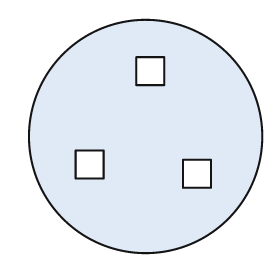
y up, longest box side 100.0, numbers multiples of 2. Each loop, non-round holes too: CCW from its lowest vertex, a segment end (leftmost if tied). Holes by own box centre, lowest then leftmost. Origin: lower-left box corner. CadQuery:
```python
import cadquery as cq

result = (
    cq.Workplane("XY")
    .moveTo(50.0, 50.0)
    .circle(50.0)
    .moveTo(66.0, 28.0)
    .lineTo(78.0, 28.0)
    .lineTo(78.0, 40.0)
    .lineTo(66.0, 40.0)
    .close()
    .moveTo(20.0, 32.0)
    .lineTo(32.0, 32.0)
    .lineTo(32.0, 44.0)
    .lineTo(20.0, 44.0)
    .close()
    .moveTo(46.0, 72.0)
    .lineTo(58.0, 72.0)
    .lineTo(58.0, 84.0)
    .lineTo(46.0, 84.0)
    .close()
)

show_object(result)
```